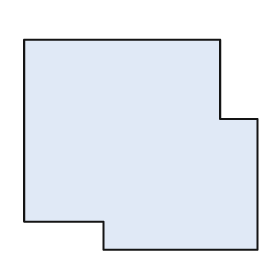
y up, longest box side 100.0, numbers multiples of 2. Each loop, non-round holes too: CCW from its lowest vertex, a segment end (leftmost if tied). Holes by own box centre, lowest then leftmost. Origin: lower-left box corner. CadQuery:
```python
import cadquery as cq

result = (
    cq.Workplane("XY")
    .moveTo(34.0, 0.0)
    .lineTo(100.0, 0.0)
    .lineTo(100.0, 56.0)
    .lineTo(84.0, 56.0)
    .lineTo(84.0, 90.0)
    .lineTo(0.0, 90.0)
    .lineTo(0.0, 12.0)
    .lineTo(34.0, 12.0)
    .close()
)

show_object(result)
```